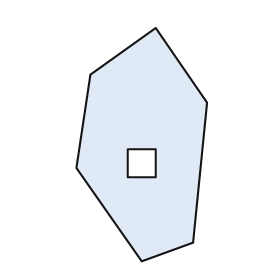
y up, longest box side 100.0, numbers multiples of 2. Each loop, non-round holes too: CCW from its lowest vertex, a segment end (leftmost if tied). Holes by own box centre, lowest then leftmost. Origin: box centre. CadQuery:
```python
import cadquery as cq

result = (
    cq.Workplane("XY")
    .moveTo(0.0, -50.0)
    .lineTo(22.0, -42.0)
    .lineTo(28.0, 18.0)
    .lineTo(6.0, 50.0)
    .lineTo(-22.0, 30.0)
    .lineTo(-28.0, -10.0)
    .close()
    .moveTo(-6.0, -14.0)
    .lineTo(6.0, -14.0)
    .lineTo(6.0, -2.0)
    .lineTo(-6.0, -2.0)
    .close()
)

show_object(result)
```